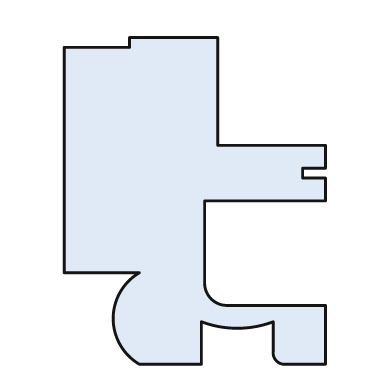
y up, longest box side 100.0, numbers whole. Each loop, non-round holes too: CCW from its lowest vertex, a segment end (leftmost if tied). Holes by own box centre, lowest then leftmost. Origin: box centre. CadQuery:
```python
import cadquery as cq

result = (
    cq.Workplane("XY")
    .moveTo(-17.0, -50.0)
    .lineTo(2.0, -50.0)
    .lineTo(2.0, -37.0)
    .threePointArc((13.0, -39.0), (24.0, -37.0))
    .lineTo(24.0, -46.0)
    .threePointArc((25.0, -49.0), (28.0, -50.0))
    .lineTo(40.0, -50.0)
    .lineTo(40.0, -32.0)
    .lineTo(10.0, -32.0)
    .threePointArc((5.0, -30.0), (3.0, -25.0))
    .lineTo(3.0, 0.0)
    .lineTo(40.0, 0.0)
    .lineTo(40.0, 7.0)
    .lineTo(33.0, 7.0)
    .lineTo(33.0, 10.0)
    .lineTo(40.0, 10.0)
    .lineTo(40.0, 17.0)
    .lineTo(7.0, 17.0)
    .lineTo(7.0, 50.0)
    .lineTo(-20.0, 50.0)
    .lineTo(-20.0, 47.0)
    .lineTo(-40.0, 47.0)
    .lineTo(-40.0, -22.0)
    .lineTo(-17.0, -22.0)
    .threePointArc((-25.0, -36.0), (-17.0, -50.0))
    .close()
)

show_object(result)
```